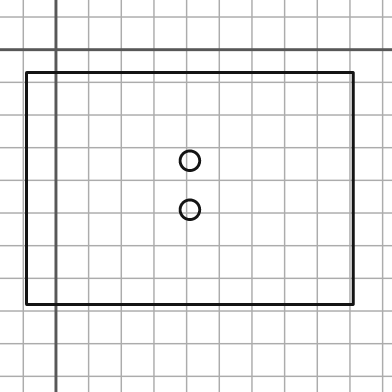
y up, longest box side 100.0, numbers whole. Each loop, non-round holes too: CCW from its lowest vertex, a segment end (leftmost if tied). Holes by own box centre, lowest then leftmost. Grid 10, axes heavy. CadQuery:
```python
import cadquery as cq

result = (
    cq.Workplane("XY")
    .moveTo(-9.0, -78.0)
    .lineTo(91.0, -78.0)
    .lineTo(91.0, -7.0)
    .lineTo(-9.0, -7.0)
    .close()
    .moveTo(41.0, -49.0)
    .circle(3.0)
    .moveTo(41.0, -34.0)
    .circle(3.0)
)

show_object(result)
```